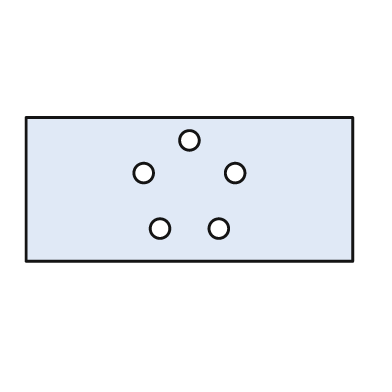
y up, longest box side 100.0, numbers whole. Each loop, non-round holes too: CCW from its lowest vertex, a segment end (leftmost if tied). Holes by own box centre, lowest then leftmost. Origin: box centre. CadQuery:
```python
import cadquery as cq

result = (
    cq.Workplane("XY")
    .moveTo(-50.0, -22.0)
    .lineTo(50.0, -22.0)
    .lineTo(50.0, 22.0)
    .lineTo(-50.0, 22.0)
    .close()
    .moveTo(-9.0, -12.0)
    .circle(3.0)
    .moveTo(9.0, -12.0)
    .circle(3.0)
    .moveTo(-14.0, 5.0)
    .circle(3.0)
    .moveTo(14.0, 5.0)
    .circle(3.0)
    .moveTo(0.0, 15.0)
    .circle(3.0)
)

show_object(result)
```